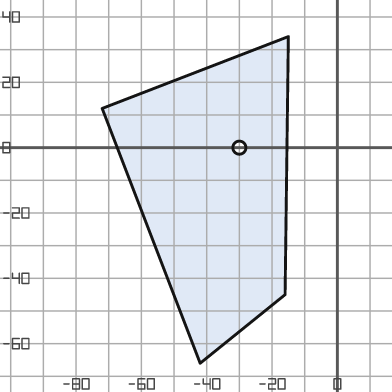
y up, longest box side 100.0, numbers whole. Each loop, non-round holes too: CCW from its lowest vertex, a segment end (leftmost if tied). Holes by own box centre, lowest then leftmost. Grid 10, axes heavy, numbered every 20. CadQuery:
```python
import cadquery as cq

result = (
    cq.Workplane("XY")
    .moveTo(-42.0, -66.0)
    .lineTo(-16.0, -45.0)
    .lineTo(-15.0, 34.0)
    .lineTo(-72.0, 12.0)
    .close()
    .moveTo(-30.0, 0.0)
    .circle(2.0)
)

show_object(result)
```